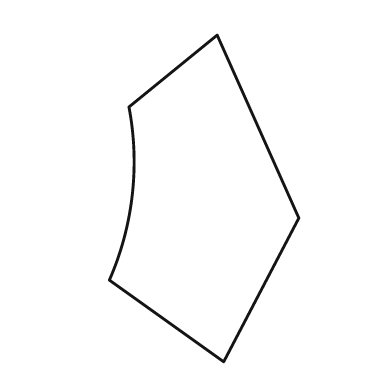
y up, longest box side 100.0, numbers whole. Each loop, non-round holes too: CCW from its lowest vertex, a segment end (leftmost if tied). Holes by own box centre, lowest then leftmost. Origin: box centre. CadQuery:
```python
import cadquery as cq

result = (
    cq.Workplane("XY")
    .moveTo(6.0, -50.0)
    .lineTo(29.0, -6.0)
    .lineTo(4.0, 50.0)
    .lineTo(-23.0, 28.0)
    .threePointArc((-22.0, 1.0), (-29.0, -25.0))
    .close()
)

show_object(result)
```